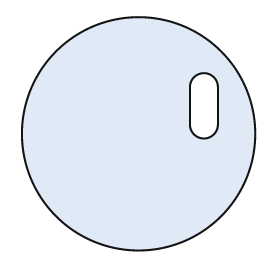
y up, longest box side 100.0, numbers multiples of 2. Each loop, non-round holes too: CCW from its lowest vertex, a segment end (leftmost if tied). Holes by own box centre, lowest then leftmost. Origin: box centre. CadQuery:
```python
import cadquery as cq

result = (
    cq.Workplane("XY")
    .moveTo(0.0, 0.0)
    .circle(50.0)
    .moveTo(22.0, 4.0)
    .threePointArc((28.0, -2.0), (34.0, 4.0))
    .lineTo(34.0, 20.0)
    .threePointArc((28.0, 26.0), (22.0, 20.0))
    .close()
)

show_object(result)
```